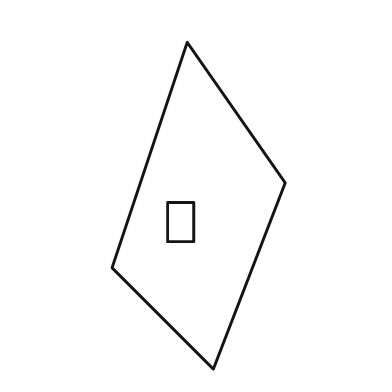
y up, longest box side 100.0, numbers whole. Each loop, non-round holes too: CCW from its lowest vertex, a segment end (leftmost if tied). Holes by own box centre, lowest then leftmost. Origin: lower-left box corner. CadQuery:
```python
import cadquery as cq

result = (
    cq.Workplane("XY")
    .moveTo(31.0, 0.0)
    .lineTo(53.0, 57.0)
    .lineTo(23.0, 100.0)
    .lineTo(0.0, 31.0)
    .close()
    .moveTo(17.0, 39.0)
    .lineTo(25.0, 39.0)
    .lineTo(25.0, 51.0)
    .lineTo(17.0, 51.0)
    .close()
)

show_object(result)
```